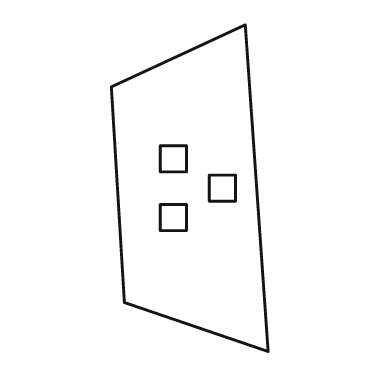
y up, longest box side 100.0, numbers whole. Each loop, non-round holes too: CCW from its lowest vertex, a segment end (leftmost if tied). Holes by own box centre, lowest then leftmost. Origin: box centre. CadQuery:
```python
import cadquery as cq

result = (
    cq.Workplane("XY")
    .moveTo(24.0, -50.0)
    .lineTo(17.0, 50.0)
    .lineTo(-24.0, 31.0)
    .lineTo(-20.0, -35.0)
    .close()
    .moveTo(-9.0, -13.0)
    .lineTo(-1.0, -13.0)
    .lineTo(-1.0, -5.0)
    .lineTo(-9.0, -5.0)
    .close()
    .moveTo(6.0, -4.0)
    .lineTo(14.0, -4.0)
    .lineTo(14.0, 4.0)
    .lineTo(6.0, 4.0)
    .close()
    .moveTo(-9.0, 5.0)
    .lineTo(-1.0, 5.0)
    .lineTo(-1.0, 13.0)
    .lineTo(-9.0, 13.0)
    .close()
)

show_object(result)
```